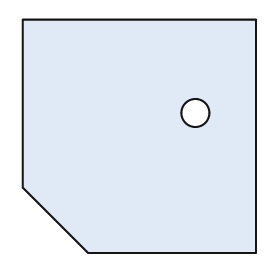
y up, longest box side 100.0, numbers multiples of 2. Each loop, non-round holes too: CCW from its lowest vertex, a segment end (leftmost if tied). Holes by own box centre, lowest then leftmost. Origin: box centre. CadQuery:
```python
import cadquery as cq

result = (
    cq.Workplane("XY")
    .moveTo(-22.0, -50.0)
    .lineTo(50.0, -50.0)
    .lineTo(50.0, 50.0)
    .lineTo(-50.0, 50.0)
    .lineTo(-50.0, -22.0)
    .close()
    .moveTo(24.0, 10.0)
    .circle(6.0)
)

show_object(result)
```